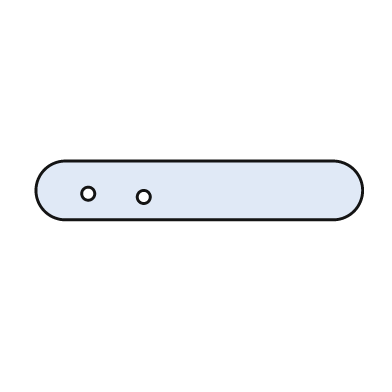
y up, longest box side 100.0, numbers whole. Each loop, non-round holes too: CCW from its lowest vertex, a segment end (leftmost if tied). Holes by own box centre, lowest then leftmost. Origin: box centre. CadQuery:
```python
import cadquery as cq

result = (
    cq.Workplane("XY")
    .moveTo(-41.0, -9.0)
    .lineTo(41.0, -9.0)
    .threePointArc((50.0, 0.0), (41.0, 9.0))
    .lineTo(-41.0, 9.0)
    .threePointArc((-50.0, 0.0), (-41.0, -9.0))
    .close()
    .moveTo(-17.0, -2.0)
    .circle(2.0)
    .moveTo(-34.0, -1.0)
    .circle(2.0)
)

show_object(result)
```